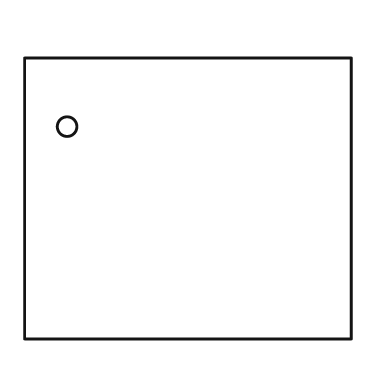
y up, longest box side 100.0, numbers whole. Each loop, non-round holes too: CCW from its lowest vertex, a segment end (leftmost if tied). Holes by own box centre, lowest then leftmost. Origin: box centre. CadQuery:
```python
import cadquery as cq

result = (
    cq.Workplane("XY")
    .moveTo(-50.0, -43.0)
    .lineTo(50.0, -43.0)
    .lineTo(50.0, 43.0)
    .lineTo(-50.0, 43.0)
    .close()
    .moveTo(-37.0, 22.0)
    .circle(3.0)
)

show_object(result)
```